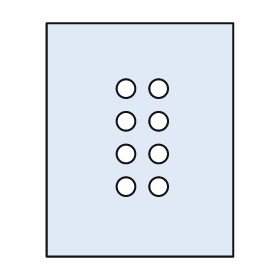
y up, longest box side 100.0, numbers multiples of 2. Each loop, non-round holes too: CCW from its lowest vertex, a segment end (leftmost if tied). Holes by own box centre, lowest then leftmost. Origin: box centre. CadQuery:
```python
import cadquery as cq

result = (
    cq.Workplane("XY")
    .moveTo(-40.0, -50.0)
    .lineTo(40.0, -50.0)
    .lineTo(40.0, 50.0)
    .lineTo(-40.0, 50.0)
    .close()
    .moveTo(-6.0, -20.0)
    .circle(4.0)
    .moveTo(8.0, -20.0)
    .circle(4.0)
    .moveTo(-6.0, -6.0)
    .circle(4.0)
    .moveTo(8.0, -6.0)
    .circle(4.0)
    .moveTo(-6.0, 8.0)
    .circle(4.0)
    .moveTo(8.0, 8.0)
    .circle(4.0)
    .moveTo(-6.0, 22.0)
    .circle(4.0)
    .moveTo(8.0, 22.0)
    .circle(4.0)
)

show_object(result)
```